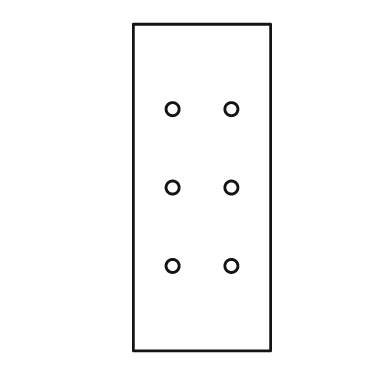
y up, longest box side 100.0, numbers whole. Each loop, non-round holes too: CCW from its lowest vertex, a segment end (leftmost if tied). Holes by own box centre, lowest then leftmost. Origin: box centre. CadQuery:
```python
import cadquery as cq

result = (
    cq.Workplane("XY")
    .moveTo(-21.0, -50.0)
    .lineTo(21.0, -50.0)
    .lineTo(21.0, 50.0)
    .lineTo(-21.0, 50.0)
    .close()
    .moveTo(-9.0, -24.0)
    .circle(2.0)
    .moveTo(9.0, -24.0)
    .circle(2.0)
    .moveTo(-9.0, 0.0)
    .circle(2.0)
    .moveTo(9.0, 0.0)
    .circle(2.0)
    .moveTo(-9.0, 24.0)
    .circle(2.0)
    .moveTo(9.0, 24.0)
    .circle(2.0)
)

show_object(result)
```